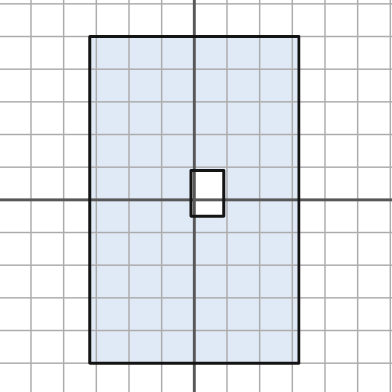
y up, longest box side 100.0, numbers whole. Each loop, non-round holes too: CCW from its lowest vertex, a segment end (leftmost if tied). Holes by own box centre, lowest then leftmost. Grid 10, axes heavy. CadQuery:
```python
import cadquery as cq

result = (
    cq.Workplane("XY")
    .moveTo(-32.0, -50.0)
    .lineTo(32.0, -50.0)
    .lineTo(32.0, 50.0)
    .lineTo(-32.0, 50.0)
    .close()
    .moveTo(-1.0, -5.0)
    .lineTo(9.0, -5.0)
    .lineTo(9.0, 9.0)
    .lineTo(-1.0, 9.0)
    .close()
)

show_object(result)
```